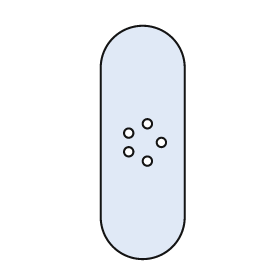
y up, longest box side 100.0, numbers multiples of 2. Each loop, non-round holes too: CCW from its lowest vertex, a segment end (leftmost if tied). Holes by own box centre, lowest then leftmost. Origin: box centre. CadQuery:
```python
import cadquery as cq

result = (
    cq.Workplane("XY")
    .moveTo(-18.0, -32.0)
    .threePointArc((0.0, -50.0), (18.0, -32.0))
    .lineTo(18.0, 32.0)
    .threePointArc((0.0, 50.0), (-18.0, 32.0))
    .close()
    .moveTo(2.0, -8.0)
    .circle(2.0)
    .moveTo(-6.0, -4.0)
    .circle(2.0)
    .moveTo(8.0, 0.0)
    .circle(2.0)
    .moveTo(-6.0, 4.0)
    .circle(2.0)
    .moveTo(2.0, 8.0)
    .circle(2.0)
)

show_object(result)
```